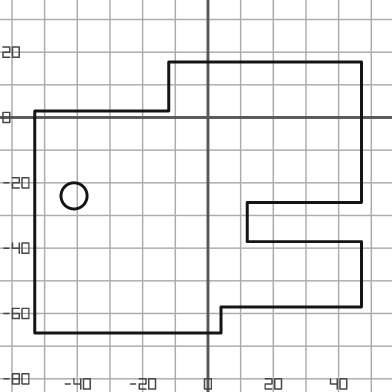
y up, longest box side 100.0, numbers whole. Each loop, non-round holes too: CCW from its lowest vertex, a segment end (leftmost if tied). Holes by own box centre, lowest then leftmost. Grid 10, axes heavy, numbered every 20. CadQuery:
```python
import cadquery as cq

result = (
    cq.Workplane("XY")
    .moveTo(-53.0, -66.0)
    .lineTo(4.0, -66.0)
    .lineTo(4.0, -58.0)
    .lineTo(47.0, -58.0)
    .lineTo(47.0, -38.0)
    .lineTo(12.0, -38.0)
    .lineTo(12.0, -26.0)
    .lineTo(47.0, -26.0)
    .lineTo(47.0, 17.0)
    .lineTo(-12.0, 17.0)
    .lineTo(-12.0, 2.0)
    .lineTo(-53.0, 2.0)
    .close()
    .moveTo(-41.0, -24.0)
    .circle(4.0)
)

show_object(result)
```